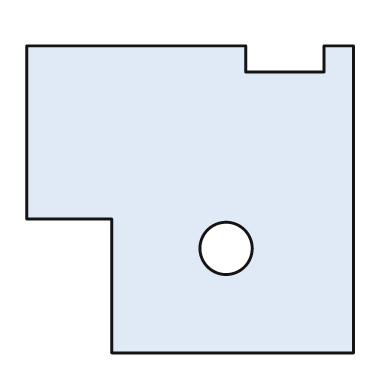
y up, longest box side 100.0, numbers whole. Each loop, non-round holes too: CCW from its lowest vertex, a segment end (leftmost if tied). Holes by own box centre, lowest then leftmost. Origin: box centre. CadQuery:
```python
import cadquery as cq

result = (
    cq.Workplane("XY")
    .moveTo(-24.0, -47.0)
    .lineTo(50.0, -47.0)
    .lineTo(50.0, 47.0)
    .lineTo(41.0, 47.0)
    .lineTo(41.0, 39.0)
    .lineTo(17.0, 39.0)
    .lineTo(17.0, 47.0)
    .lineTo(-50.0, 47.0)
    .lineTo(-50.0, -6.0)
    .lineTo(-24.0, -6.0)
    .close()
    .moveTo(11.0, -15.0)
    .circle(8.0)
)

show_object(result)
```